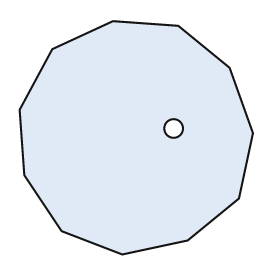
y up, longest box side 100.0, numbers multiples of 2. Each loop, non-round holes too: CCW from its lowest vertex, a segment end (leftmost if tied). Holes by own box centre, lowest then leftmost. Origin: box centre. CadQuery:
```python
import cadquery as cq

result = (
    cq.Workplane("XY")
    .moveTo(-6.0, -50.0)
    .lineTo(22.0, -44.0)
    .lineTo(44.0, -26.0)
    .lineTo(50.0, 2.0)
    .lineTo(40.0, 30.0)
    .lineTo(18.0, 48.0)
    .lineTo(-10.0, 50.0)
    .lineTo(-36.0, 38.0)
    .lineTo(-50.0, 12.0)
    .lineTo(-48.0, -16.0)
    .lineTo(-32.0, -40.0)
    .close()
    .moveTo(16.0, 4.0)
    .circle(4.0)
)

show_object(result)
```